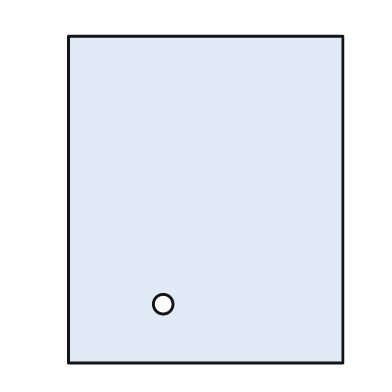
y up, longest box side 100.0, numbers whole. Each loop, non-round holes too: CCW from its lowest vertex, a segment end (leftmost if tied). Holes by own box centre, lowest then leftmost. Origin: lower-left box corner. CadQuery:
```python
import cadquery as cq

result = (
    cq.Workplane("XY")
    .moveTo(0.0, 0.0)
    .lineTo(84.0, 0.0)
    .lineTo(84.0, 100.0)
    .lineTo(0.0, 100.0)
    .close()
    .moveTo(29.0, 18.0)
    .circle(3.0)
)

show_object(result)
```